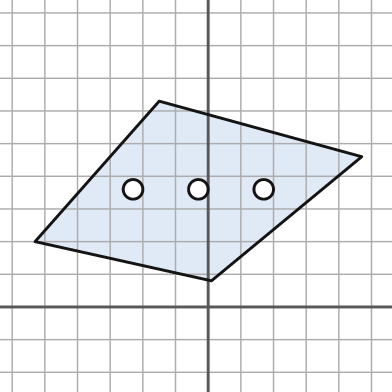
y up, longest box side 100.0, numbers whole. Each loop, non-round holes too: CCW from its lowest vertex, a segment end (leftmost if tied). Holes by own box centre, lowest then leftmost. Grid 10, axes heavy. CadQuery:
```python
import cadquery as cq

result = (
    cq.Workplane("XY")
    .moveTo(1.0, 8.0)
    .lineTo(47.0, 46.0)
    .lineTo(-15.0, 63.0)
    .lineTo(-53.0, 20.0)
    .close()
    .moveTo(-23.0, 36.0)
    .circle(3.0)
    .moveTo(-3.0, 36.0)
    .circle(3.0)
    .moveTo(17.0, 36.0)
    .circle(3.0)
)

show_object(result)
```